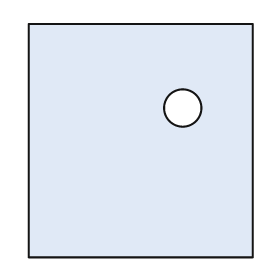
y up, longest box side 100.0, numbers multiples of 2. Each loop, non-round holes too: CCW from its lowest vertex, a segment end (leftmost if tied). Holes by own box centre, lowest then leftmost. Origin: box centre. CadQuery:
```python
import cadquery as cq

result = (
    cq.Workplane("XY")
    .moveTo(-48.0, -50.0)
    .lineTo(48.0, -50.0)
    .lineTo(48.0, 50.0)
    .lineTo(-48.0, 50.0)
    .close()
    .moveTo(18.0, 14.0)
    .circle(8.0)
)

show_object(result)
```